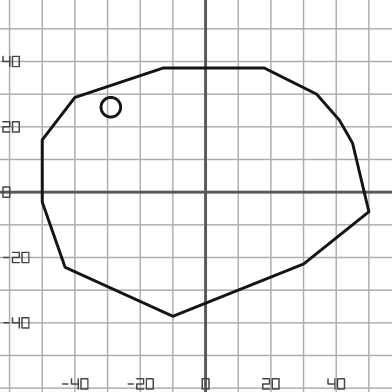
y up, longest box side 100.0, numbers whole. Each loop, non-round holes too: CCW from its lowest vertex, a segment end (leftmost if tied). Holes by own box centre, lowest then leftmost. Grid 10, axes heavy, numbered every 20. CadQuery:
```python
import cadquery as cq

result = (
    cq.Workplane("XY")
    .moveTo(-10.0, -38.0)
    .lineTo(30.0, -22.0)
    .lineTo(50.0, -6.0)
    .lineTo(45.0, 15.0)
    .lineTo(41.0, 22.0)
    .lineTo(34.0, 30.0)
    .lineTo(18.0, 38.0)
    .lineTo(-13.0, 38.0)
    .lineTo(-40.0, 29.0)
    .lineTo(-50.0, 16.0)
    .lineTo(-50.0, -3.0)
    .lineTo(-43.0, -23.0)
    .close()
    .moveTo(-29.0, 26.0)
    .circle(3.0)
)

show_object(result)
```